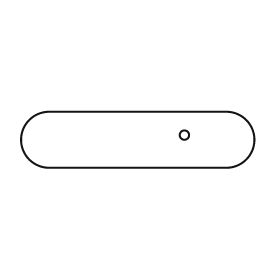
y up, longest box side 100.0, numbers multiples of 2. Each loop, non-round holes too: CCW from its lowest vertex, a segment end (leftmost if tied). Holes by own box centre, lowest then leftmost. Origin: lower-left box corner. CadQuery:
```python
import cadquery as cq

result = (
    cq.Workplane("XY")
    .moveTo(12.0, 0.0)
    .lineTo(88.0, 0.0)
    .threePointArc((100.0, 12.0), (88.0, 24.0))
    .lineTo(12.0, 24.0)
    .threePointArc((0.0, 12.0), (12.0, 0.0))
    .close()
    .moveTo(70.0, 14.0)
    .circle(2.0)
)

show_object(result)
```